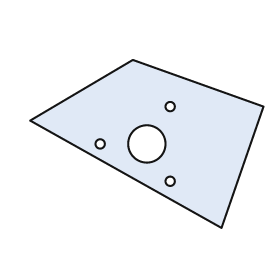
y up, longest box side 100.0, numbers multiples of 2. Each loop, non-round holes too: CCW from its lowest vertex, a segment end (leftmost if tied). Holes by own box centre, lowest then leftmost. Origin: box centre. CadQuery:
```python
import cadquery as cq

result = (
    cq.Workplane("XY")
    .moveTo(32.0, -36.0)
    .lineTo(50.0, 16.0)
    .lineTo(-6.0, 36.0)
    .lineTo(-50.0, 10.0)
    .close()
    .moveTo(10.0, -16.0)
    .circle(2.0)
    .moveTo(-20.0, 0.0)
    .circle(2.0)
    .moveTo(0.0, 0.0)
    .circle(8.0)
    .moveTo(10.0, 16.0)
    .circle(2.0)
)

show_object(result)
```